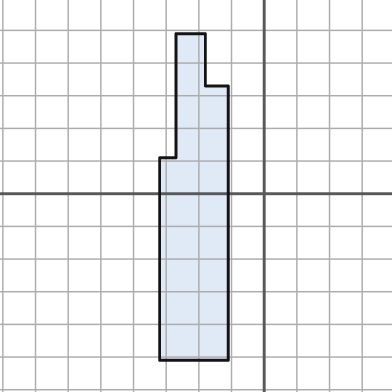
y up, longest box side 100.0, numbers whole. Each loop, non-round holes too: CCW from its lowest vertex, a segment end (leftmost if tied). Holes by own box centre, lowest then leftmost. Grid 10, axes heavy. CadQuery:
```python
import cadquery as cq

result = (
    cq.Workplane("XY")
    .moveTo(-32.0, -51.0)
    .lineTo(-11.0, -51.0)
    .lineTo(-11.0, 33.0)
    .lineTo(-18.0, 33.0)
    .lineTo(-18.0, 49.0)
    .lineTo(-27.0, 49.0)
    .lineTo(-27.0, 11.0)
    .lineTo(-32.0, 11.0)
    .close()
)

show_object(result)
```